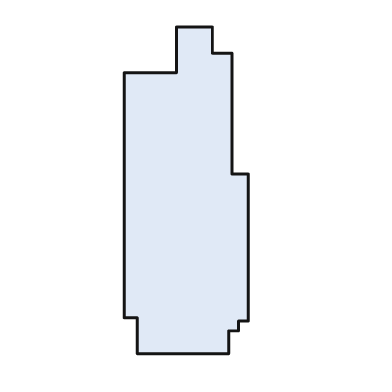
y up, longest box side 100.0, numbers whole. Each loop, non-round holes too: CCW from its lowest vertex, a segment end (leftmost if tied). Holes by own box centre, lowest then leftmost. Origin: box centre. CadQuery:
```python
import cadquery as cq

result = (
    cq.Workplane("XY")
    .moveTo(-15.0, -50.0)
    .lineTo(13.0, -50.0)
    .lineTo(13.0, -43.0)
    .lineTo(16.0, -43.0)
    .lineTo(16.0, -40.0)
    .lineTo(19.0, -40.0)
    .lineTo(19.0, 5.0)
    .lineTo(14.0, 5.0)
    .lineTo(14.0, 42.0)
    .lineTo(8.0, 42.0)
    .lineTo(8.0, 50.0)
    .lineTo(-3.0, 50.0)
    .lineTo(-3.0, 36.0)
    .lineTo(-19.0, 36.0)
    .lineTo(-19.0, -39.0)
    .lineTo(-15.0, -39.0)
    .close()
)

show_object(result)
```